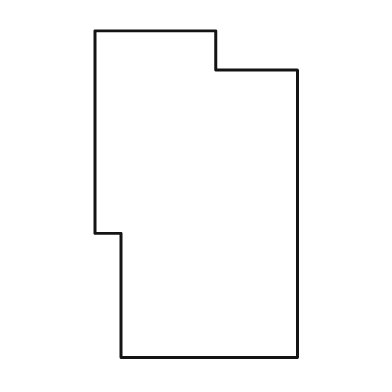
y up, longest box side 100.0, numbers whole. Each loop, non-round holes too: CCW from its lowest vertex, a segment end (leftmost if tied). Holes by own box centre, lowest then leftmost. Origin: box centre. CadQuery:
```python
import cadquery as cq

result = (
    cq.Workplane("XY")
    .moveTo(-23.0, -50.0)
    .lineTo(31.0, -50.0)
    .lineTo(31.0, 38.0)
    .lineTo(6.0, 38.0)
    .lineTo(6.0, 50.0)
    .lineTo(-31.0, 50.0)
    .lineTo(-31.0, -12.0)
    .lineTo(-23.0, -12.0)
    .close()
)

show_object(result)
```